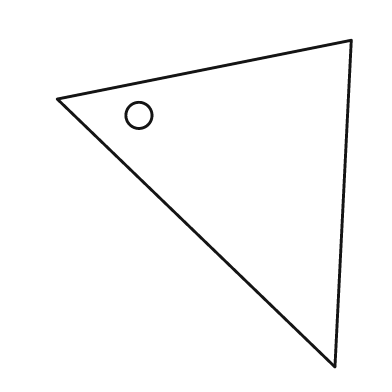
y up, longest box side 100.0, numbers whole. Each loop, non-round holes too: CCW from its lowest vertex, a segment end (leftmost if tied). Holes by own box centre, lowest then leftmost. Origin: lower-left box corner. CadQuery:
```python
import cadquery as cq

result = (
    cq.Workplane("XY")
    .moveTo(85.0, 0.0)
    .lineTo(90.0, 100.0)
    .lineTo(0.0, 82.0)
    .close()
    .moveTo(25.0, 77.0)
    .circle(4.0)
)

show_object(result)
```